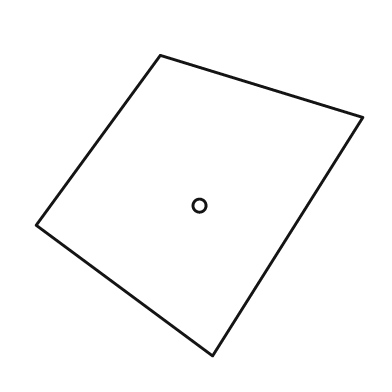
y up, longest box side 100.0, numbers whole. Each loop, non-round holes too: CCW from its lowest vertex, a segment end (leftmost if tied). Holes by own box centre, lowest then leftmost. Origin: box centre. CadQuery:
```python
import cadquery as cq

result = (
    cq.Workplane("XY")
    .moveTo(4.0, -46.0)
    .lineTo(50.0, 27.0)
    .lineTo(-12.0, 46.0)
    .lineTo(-50.0, -6.0)
    .close()
    .moveTo(0.0, 0.0)
    .circle(2.0)
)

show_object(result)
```